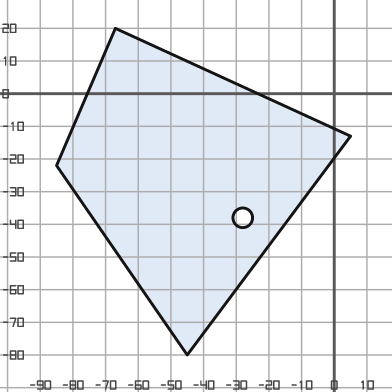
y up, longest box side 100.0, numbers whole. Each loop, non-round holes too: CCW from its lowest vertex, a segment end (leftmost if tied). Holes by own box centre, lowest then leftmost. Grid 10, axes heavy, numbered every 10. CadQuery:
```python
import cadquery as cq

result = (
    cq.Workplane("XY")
    .moveTo(-45.0, -80.0)
    .lineTo(5.0, -13.0)
    .lineTo(-67.0, 20.0)
    .lineTo(-85.0, -22.0)
    .close()
    .moveTo(-28.0, -38.0)
    .circle(3.0)
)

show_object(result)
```